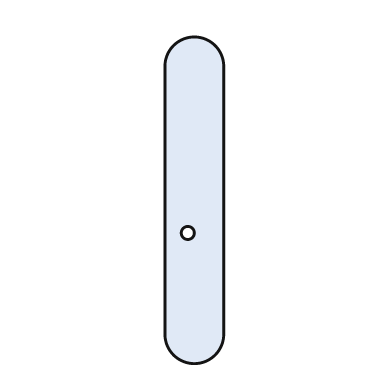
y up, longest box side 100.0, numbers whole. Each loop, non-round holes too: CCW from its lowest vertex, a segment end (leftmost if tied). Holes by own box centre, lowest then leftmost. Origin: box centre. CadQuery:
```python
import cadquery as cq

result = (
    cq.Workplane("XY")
    .moveTo(-9.0, -41.0)
    .threePointArc((0.0, -50.0), (9.0, -41.0))
    .lineTo(9.0, 41.0)
    .threePointArc((0.0, 50.0), (-9.0, 41.0))
    .close()
    .moveTo(-2.0, -10.0)
    .circle(2.0)
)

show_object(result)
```